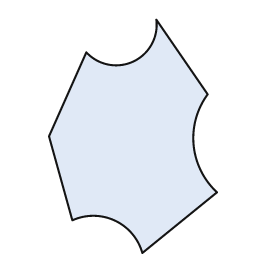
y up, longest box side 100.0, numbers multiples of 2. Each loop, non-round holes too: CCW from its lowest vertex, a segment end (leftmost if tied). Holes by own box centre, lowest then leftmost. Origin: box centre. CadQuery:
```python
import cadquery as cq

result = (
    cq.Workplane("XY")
    .moveTo(4.0, -50.0)
    .lineTo(36.0, -24.0)
    .threePointArc((26.0, -4.0), (32.0, 18.0))
    .lineTo(10.0, 50.0)
    .threePointArc((0.0, 32.0), (-20.0, 36.0))
    .lineTo(-36.0, 0.0)
    .lineTo(-26.0, -36.0)
    .threePointArc((-8.0, -36.0), (4.0, -50.0))
    .close()
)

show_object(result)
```